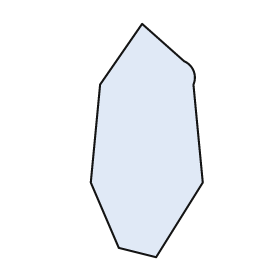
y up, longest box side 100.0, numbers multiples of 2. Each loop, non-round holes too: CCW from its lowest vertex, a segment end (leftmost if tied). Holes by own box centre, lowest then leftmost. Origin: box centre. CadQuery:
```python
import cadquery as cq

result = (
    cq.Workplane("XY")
    .moveTo(4.0, -50.0)
    .lineTo(24.0, -18.0)
    .lineTo(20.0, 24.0)
    .threePointArc((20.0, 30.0), (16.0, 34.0))
    .lineTo(-2.0, 50.0)
    .lineTo(-20.0, 24.0)
    .lineTo(-24.0, -18.0)
    .lineTo(-12.0, -46.0)
    .close()
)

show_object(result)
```